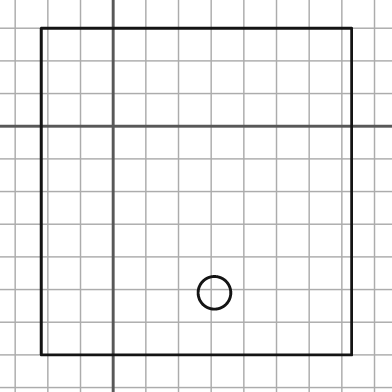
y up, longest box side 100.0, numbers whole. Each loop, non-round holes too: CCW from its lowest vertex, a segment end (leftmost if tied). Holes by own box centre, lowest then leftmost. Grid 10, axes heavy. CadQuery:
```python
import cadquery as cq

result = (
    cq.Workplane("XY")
    .moveTo(-22.0, -70.0)
    .lineTo(73.0, -70.0)
    .lineTo(73.0, 30.0)
    .lineTo(-22.0, 30.0)
    .close()
    .moveTo(31.0, -51.0)
    .circle(5.0)
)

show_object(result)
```